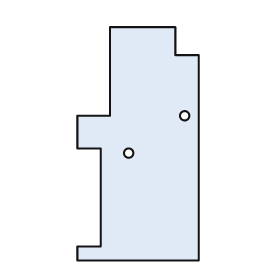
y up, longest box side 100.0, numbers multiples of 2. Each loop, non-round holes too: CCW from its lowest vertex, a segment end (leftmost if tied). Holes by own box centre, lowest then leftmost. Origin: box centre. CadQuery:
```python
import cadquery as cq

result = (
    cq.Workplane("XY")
    .moveTo(-26.0, -50.0)
    .lineTo(26.0, -50.0)
    .lineTo(26.0, 38.0)
    .lineTo(16.0, 38.0)
    .lineTo(16.0, 50.0)
    .lineTo(-12.0, 50.0)
    .lineTo(-12.0, 12.0)
    .lineTo(-26.0, 12.0)
    .lineTo(-26.0, -2.0)
    .lineTo(-16.0, -2.0)
    .lineTo(-16.0, -44.0)
    .lineTo(-26.0, -44.0)
    .close()
    .moveTo(-4.0, -4.0)
    .circle(2.0)
    .moveTo(20.0, 12.0)
    .circle(2.0)
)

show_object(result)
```